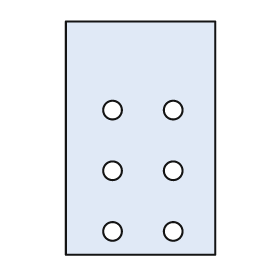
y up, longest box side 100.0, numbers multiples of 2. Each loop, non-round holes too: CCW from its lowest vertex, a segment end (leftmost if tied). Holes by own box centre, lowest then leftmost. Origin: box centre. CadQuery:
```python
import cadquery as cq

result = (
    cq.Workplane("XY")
    .moveTo(-32.0, -50.0)
    .lineTo(32.0, -50.0)
    .lineTo(32.0, 50.0)
    .lineTo(-32.0, 50.0)
    .close()
    .moveTo(-12.0, -40.0)
    .circle(4.0)
    .moveTo(14.0, -40.0)
    .circle(4.0)
    .moveTo(-12.0, -14.0)
    .circle(4.0)
    .moveTo(14.0, -14.0)
    .circle(4.0)
    .moveTo(-12.0, 12.0)
    .circle(4.0)
    .moveTo(14.0, 12.0)
    .circle(4.0)
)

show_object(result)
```